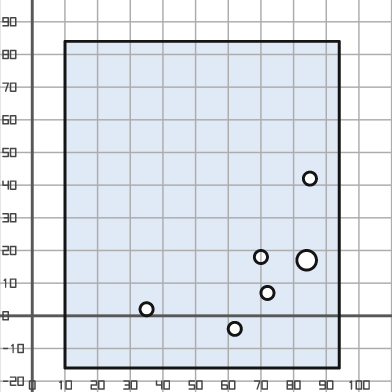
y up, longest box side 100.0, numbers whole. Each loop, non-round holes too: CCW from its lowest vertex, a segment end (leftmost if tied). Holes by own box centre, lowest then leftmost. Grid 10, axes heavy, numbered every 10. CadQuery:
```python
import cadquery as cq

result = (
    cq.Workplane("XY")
    .moveTo(10.0, -16.0)
    .lineTo(94.0, -16.0)
    .lineTo(94.0, 84.0)
    .lineTo(10.0, 84.0)
    .close()
    .moveTo(62.0, -4.0)
    .circle(2.0)
    .moveTo(35.0, 2.0)
    .circle(2.0)
    .moveTo(72.0, 7.0)
    .circle(2.0)
    .moveTo(84.0, 17.0)
    .circle(3.0)
    .moveTo(70.0, 18.0)
    .circle(2.0)
    .moveTo(85.0, 42.0)
    .circle(2.0)
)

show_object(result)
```